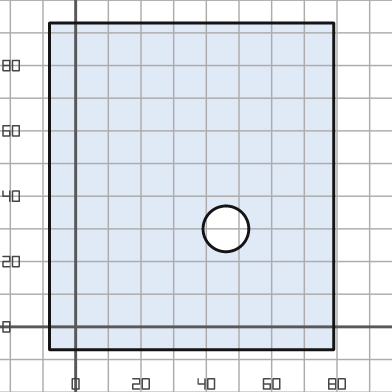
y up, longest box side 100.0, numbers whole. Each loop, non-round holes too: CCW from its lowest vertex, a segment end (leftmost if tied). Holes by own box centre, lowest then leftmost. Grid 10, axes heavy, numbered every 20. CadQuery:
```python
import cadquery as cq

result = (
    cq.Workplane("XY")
    .moveTo(-8.0, -7.0)
    .lineTo(79.0, -7.0)
    .lineTo(79.0, 93.0)
    .lineTo(-8.0, 93.0)
    .close()
    .moveTo(46.0, 30.0)
    .circle(7.0)
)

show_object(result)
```